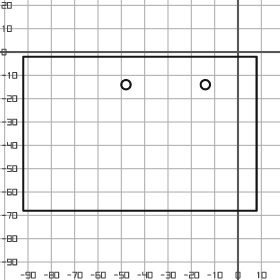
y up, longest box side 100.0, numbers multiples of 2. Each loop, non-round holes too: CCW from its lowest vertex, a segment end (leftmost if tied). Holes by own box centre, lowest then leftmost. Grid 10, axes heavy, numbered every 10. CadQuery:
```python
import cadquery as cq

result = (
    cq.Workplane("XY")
    .moveTo(-92.0, -68.0)
    .lineTo(8.0, -68.0)
    .lineTo(8.0, -2.0)
    .lineTo(-92.0, -2.0)
    .close()
    .moveTo(-48.0, -14.0)
    .circle(2.0)
    .moveTo(-14.0, -14.0)
    .circle(2.0)
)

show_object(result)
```